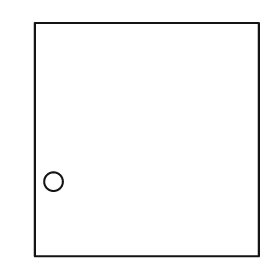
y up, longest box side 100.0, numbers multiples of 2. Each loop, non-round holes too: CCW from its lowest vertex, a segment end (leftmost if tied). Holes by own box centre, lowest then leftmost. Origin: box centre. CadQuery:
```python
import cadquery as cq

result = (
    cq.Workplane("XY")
    .moveTo(-48.0, -50.0)
    .lineTo(48.0, -50.0)
    .lineTo(48.0, 50.0)
    .lineTo(-48.0, 50.0)
    .close()
    .moveTo(-40.0, -18.0)
    .circle(4.0)
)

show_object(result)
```